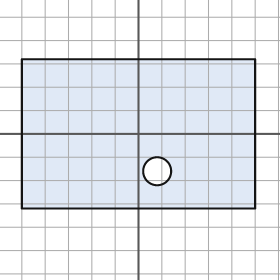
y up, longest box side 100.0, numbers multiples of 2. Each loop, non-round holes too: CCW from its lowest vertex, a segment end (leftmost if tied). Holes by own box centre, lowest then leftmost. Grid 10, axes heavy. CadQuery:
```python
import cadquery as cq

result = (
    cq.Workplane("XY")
    .moveTo(-50.0, -32.0)
    .lineTo(50.0, -32.0)
    .lineTo(50.0, 32.0)
    .lineTo(-50.0, 32.0)
    .close()
    .moveTo(8.0, -16.0)
    .circle(6.0)
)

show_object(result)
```